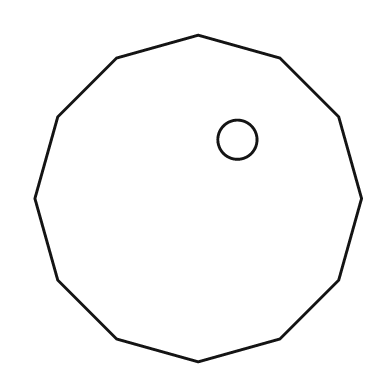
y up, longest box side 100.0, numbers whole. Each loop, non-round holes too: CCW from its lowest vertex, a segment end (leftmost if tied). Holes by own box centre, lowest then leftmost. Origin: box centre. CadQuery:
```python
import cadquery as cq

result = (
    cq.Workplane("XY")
    .moveTo(0.0, -50.0)
    .lineTo(25.0, -43.0)
    .lineTo(43.0, -25.0)
    .lineTo(50.0, 0.0)
    .lineTo(43.0, 25.0)
    .lineTo(25.0, 43.0)
    .lineTo(0.0, 50.0)
    .lineTo(-25.0, 43.0)
    .lineTo(-43.0, 25.0)
    .lineTo(-50.0, 0.0)
    .lineTo(-43.0, -25.0)
    .lineTo(-25.0, -43.0)
    .close()
    .moveTo(12.0, 18.0)
    .circle(6.0)
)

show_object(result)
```